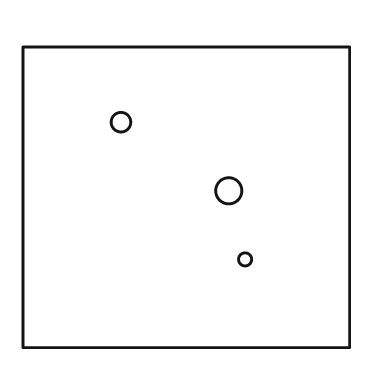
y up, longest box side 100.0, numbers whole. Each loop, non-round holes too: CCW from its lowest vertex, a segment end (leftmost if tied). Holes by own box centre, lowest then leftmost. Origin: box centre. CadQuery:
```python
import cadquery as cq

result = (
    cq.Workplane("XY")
    .moveTo(-50.0, -46.0)
    .lineTo(50.0, -46.0)
    .lineTo(50.0, 46.0)
    .lineTo(-50.0, 46.0)
    .close()
    .moveTo(18.0, -19.0)
    .circle(2.0)
    .moveTo(13.0, 2.0)
    .circle(4.0)
    .moveTo(-20.0, 23.0)
    .circle(3.0)
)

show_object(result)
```